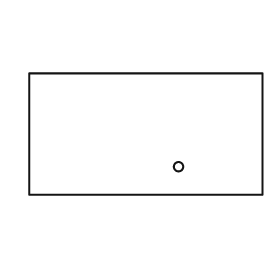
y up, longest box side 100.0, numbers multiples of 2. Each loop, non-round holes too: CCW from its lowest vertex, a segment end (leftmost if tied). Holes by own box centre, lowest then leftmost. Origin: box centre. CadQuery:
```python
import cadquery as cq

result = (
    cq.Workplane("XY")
    .moveTo(-50.0, -26.0)
    .lineTo(50.0, -26.0)
    .lineTo(50.0, 26.0)
    .lineTo(-50.0, 26.0)
    .close()
    .moveTo(14.0, -14.0)
    .circle(2.0)
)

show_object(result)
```